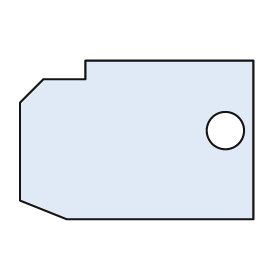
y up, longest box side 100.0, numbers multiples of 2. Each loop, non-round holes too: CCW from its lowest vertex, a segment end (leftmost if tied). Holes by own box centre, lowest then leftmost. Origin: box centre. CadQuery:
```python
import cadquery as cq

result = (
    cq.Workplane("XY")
    .moveTo(-30.0, -34.0)
    .lineTo(50.0, -34.0)
    .lineTo(50.0, 34.0)
    .lineTo(-22.0, 34.0)
    .lineTo(-22.0, 26.0)
    .lineTo(-40.0, 26.0)
    .lineTo(-50.0, 16.0)
    .lineTo(-50.0, -26.0)
    .close()
    .moveTo(38.0, 4.0)
    .circle(8.0)
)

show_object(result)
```